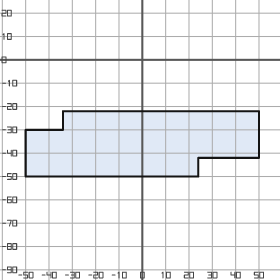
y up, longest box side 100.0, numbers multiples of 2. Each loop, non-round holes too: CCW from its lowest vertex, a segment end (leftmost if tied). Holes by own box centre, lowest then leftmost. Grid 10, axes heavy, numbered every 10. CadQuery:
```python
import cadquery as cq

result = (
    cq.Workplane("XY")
    .moveTo(-50.0, -50.0)
    .lineTo(24.0, -50.0)
    .lineTo(24.0, -42.0)
    .lineTo(50.0, -42.0)
    .lineTo(50.0, -22.0)
    .lineTo(-34.0, -22.0)
    .lineTo(-34.0, -30.0)
    .lineTo(-50.0, -30.0)
    .close()
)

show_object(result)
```